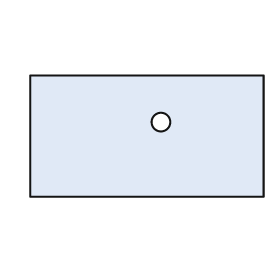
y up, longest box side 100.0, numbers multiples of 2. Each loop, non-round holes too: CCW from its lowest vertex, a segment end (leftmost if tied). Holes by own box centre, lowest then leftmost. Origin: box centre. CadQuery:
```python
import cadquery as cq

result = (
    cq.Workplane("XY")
    .moveTo(-50.0, -26.0)
    .lineTo(50.0, -26.0)
    .lineTo(50.0, 26.0)
    .lineTo(-50.0, 26.0)
    .close()
    .moveTo(6.0, 6.0)
    .circle(4.0)
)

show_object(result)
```